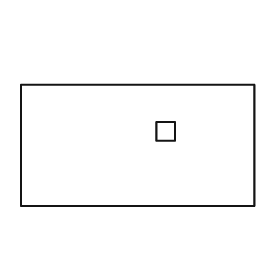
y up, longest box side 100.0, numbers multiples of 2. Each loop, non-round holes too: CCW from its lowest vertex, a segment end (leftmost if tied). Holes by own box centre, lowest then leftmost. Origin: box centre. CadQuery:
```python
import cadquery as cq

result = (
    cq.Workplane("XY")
    .moveTo(-50.0, -26.0)
    .lineTo(50.0, -26.0)
    .lineTo(50.0, 26.0)
    .lineTo(-50.0, 26.0)
    .close()
    .moveTo(8.0, 2.0)
    .lineTo(16.0, 2.0)
    .lineTo(16.0, 10.0)
    .lineTo(8.0, 10.0)
    .close()
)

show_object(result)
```